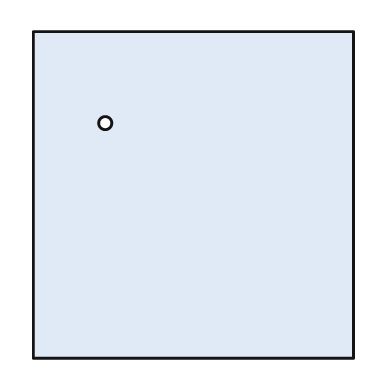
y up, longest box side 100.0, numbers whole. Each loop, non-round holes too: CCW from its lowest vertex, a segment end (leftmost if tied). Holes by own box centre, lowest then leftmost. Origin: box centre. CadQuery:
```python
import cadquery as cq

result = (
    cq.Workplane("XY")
    .moveTo(-49.0, -50.0)
    .lineTo(49.0, -50.0)
    .lineTo(49.0, 50.0)
    .lineTo(-49.0, 50.0)
    .close()
    .moveTo(-27.0, 22.0)
    .circle(2.0)
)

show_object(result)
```